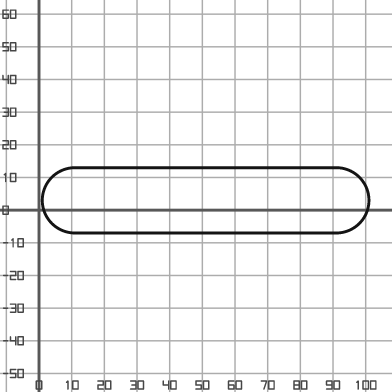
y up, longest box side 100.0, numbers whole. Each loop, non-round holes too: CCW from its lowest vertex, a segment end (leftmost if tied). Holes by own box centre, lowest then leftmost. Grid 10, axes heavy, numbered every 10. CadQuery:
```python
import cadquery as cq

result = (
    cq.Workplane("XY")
    .moveTo(11.0, -7.0)
    .lineTo(91.0, -7.0)
    .threePointArc((101.0, 3.0), (91.0, 13.0))
    .lineTo(11.0, 13.0)
    .threePointArc((1.0, 3.0), (11.0, -7.0))
    .close()
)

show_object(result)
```